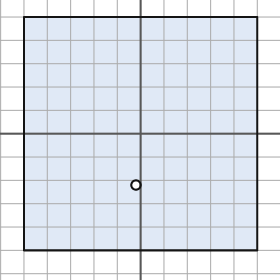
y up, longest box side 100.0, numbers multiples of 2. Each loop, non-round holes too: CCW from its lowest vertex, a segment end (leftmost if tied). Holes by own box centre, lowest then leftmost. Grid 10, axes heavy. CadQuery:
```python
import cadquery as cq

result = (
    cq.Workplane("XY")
    .moveTo(-50.0, -50.0)
    .lineTo(50.0, -50.0)
    .lineTo(50.0, 50.0)
    .lineTo(-50.0, 50.0)
    .close()
    .moveTo(-2.0, -22.0)
    .circle(2.0)
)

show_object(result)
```